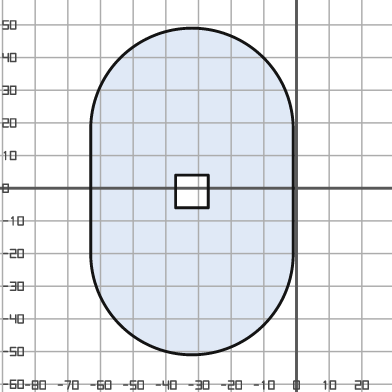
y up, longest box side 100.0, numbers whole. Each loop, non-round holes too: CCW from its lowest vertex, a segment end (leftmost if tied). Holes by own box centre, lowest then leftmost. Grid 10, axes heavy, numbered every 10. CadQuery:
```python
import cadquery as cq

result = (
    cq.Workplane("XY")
    .moveTo(-63.0, -20.0)
    .threePointArc((-32.0, -51.0), (-1.0, -20.0))
    .lineTo(-1.0, 18.0)
    .threePointArc((-32.0, 49.0), (-63.0, 18.0))
    .close()
    .moveTo(-37.0, -6.0)
    .lineTo(-27.0, -6.0)
    .lineTo(-27.0, 4.0)
    .lineTo(-37.0, 4.0)
    .close()
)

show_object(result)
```